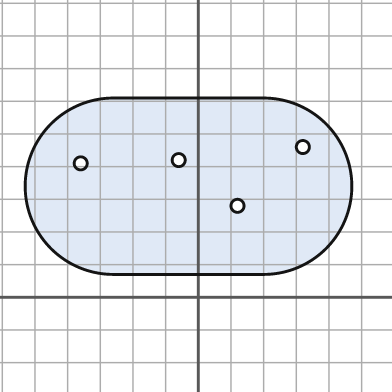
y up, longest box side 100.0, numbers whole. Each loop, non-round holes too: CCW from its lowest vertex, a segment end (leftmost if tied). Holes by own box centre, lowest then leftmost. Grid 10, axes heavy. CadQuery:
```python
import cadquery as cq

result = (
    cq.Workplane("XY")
    .moveTo(-26.0, 7.0)
    .lineTo(20.0, 7.0)
    .threePointArc((47.0, 34.0), (20.0, 61.0))
    .lineTo(-26.0, 61.0)
    .threePointArc((-53.0, 34.0), (-26.0, 7.0))
    .close()
    .moveTo(12.0, 28.0)
    .circle(2.0)
    .moveTo(-36.0, 41.0)
    .circle(2.0)
    .moveTo(-6.0, 42.0)
    .circle(2.0)
    .moveTo(32.0, 46.0)
    .circle(2.0)
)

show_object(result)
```